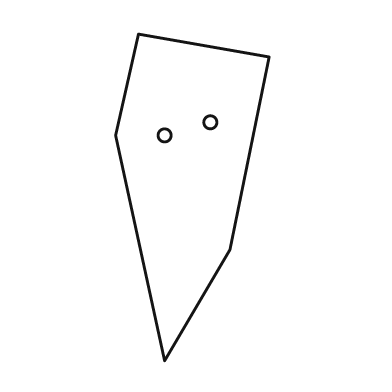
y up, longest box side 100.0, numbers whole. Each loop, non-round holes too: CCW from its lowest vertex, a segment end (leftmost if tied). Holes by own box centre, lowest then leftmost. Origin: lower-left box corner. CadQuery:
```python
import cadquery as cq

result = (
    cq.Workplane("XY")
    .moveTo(15.0, 0.0)
    .lineTo(35.0, 34.0)
    .lineTo(47.0, 93.0)
    .lineTo(7.0, 100.0)
    .lineTo(0.0, 69.0)
    .close()
    .moveTo(15.0, 69.0)
    .circle(2.0)
    .moveTo(29.0, 73.0)
    .circle(2.0)
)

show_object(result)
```